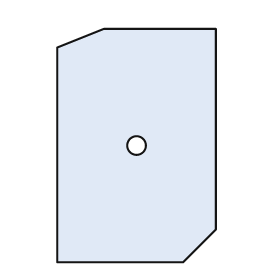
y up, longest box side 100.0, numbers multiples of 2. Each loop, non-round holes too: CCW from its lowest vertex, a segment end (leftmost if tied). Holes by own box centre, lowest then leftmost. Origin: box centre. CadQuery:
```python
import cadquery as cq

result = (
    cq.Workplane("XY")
    .moveTo(-34.0, -50.0)
    .lineTo(20.0, -50.0)
    .lineTo(34.0, -36.0)
    .lineTo(34.0, 50.0)
    .lineTo(-14.0, 50.0)
    .lineTo(-34.0, 42.0)
    .close()
    .moveTo(0.0, 0.0)
    .circle(4.0)
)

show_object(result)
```